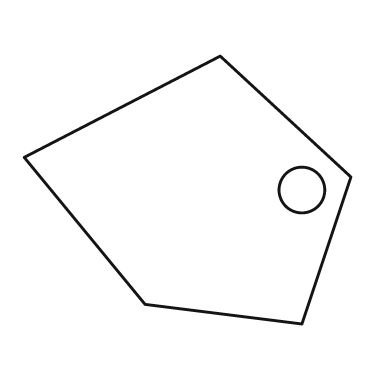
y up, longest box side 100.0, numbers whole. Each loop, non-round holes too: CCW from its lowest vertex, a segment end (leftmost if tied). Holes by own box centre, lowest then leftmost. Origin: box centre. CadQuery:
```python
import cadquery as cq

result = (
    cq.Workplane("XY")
    .moveTo(35.0, -41.0)
    .lineTo(50.0, 4.0)
    .lineTo(10.0, 41.0)
    .lineTo(-50.0, 10.0)
    .lineTo(-13.0, -35.0)
    .close()
    .moveTo(35.0, 0.0)
    .circle(7.0)
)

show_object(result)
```